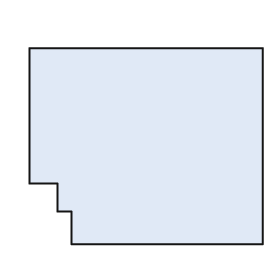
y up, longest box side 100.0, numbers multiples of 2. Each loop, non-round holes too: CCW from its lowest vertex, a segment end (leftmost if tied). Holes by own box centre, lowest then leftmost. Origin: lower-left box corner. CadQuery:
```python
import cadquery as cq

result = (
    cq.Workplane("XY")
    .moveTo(18.0, 0.0)
    .lineTo(100.0, 0.0)
    .lineTo(100.0, 84.0)
    .lineTo(0.0, 84.0)
    .lineTo(0.0, 26.0)
    .lineTo(12.0, 26.0)
    .lineTo(12.0, 14.0)
    .lineTo(18.0, 14.0)
    .close()
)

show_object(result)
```